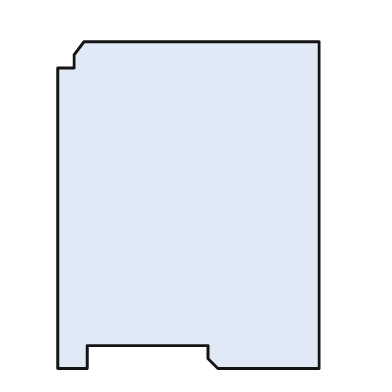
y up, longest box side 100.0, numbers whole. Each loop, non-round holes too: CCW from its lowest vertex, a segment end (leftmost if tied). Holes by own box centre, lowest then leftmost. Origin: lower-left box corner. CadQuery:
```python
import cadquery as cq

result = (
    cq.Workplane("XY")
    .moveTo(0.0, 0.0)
    .lineTo(9.0, 0.0)
    .lineTo(9.0, 7.0)
    .lineTo(46.0, 7.0)
    .lineTo(46.0, 3.0)
    .lineTo(49.0, 0.0)
    .lineTo(80.0, 0.0)
    .lineTo(80.0, 100.0)
    .lineTo(8.0, 100.0)
    .lineTo(5.0, 96.0)
    .lineTo(5.0, 92.0)
    .lineTo(0.0, 92.0)
    .close()
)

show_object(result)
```